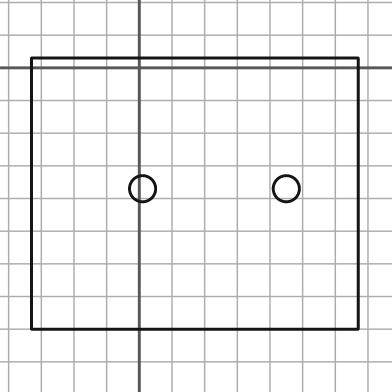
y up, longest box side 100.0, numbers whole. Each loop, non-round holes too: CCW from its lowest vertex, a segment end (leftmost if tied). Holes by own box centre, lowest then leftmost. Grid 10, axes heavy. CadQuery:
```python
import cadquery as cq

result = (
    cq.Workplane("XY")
    .moveTo(-33.0, -80.0)
    .lineTo(67.0, -80.0)
    .lineTo(67.0, 3.0)
    .lineTo(-33.0, 3.0)
    .close()
    .moveTo(1.0, -37.0)
    .circle(4.0)
    .moveTo(45.0, -37.0)
    .circle(4.0)
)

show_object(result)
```